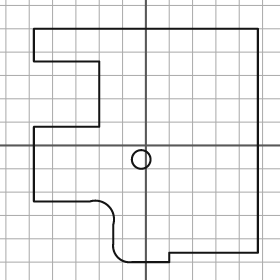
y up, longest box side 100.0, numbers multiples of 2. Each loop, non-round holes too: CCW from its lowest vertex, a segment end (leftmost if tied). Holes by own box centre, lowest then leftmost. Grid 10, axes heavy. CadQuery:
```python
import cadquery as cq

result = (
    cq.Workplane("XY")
    .moveTo(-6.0, -50.0)
    .lineTo(10.0, -50.0)
    .lineTo(10.0, -46.0)
    .lineTo(48.0, -46.0)
    .lineTo(48.0, 50.0)
    .lineTo(-48.0, 50.0)
    .lineTo(-48.0, 36.0)
    .lineTo(-20.0, 36.0)
    .lineTo(-20.0, 8.0)
    .lineTo(-48.0, 8.0)
    .lineTo(-48.0, -24.0)
    .lineTo(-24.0, -24.0)
    .threePointArc((-16.0, -26.0), (-14.0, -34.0))
    .lineTo(-14.0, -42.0)
    .threePointArc((-12.0, -48.0), (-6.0, -50.0))
    .close()
    .moveTo(-2.0, -6.0)
    .circle(4.0)
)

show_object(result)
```